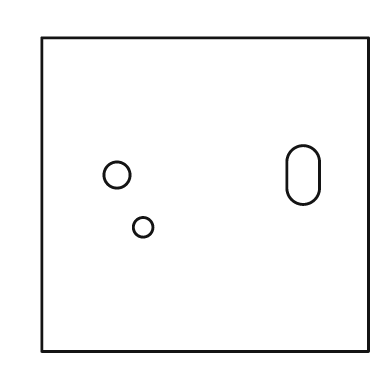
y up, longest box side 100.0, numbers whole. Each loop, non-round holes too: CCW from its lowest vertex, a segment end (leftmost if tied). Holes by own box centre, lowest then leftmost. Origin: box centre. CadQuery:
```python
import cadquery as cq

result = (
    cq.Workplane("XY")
    .moveTo(-50.0, -48.0)
    .lineTo(50.0, -48.0)
    .lineTo(50.0, 48.0)
    .lineTo(-50.0, 48.0)
    .close()
    .moveTo(-19.0, -10.0)
    .circle(3.0)
    .moveTo(-27.0, 6.0)
    .circle(4.0)
    .moveTo(25.0, 2.0)
    .threePointArc((30.0, -3.0), (35.0, 2.0))
    .lineTo(35.0, 10.0)
    .threePointArc((30.0, 15.0), (25.0, 10.0))
    .close()
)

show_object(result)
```